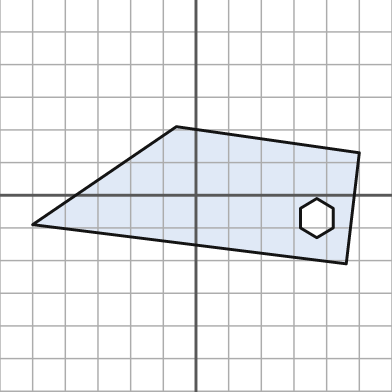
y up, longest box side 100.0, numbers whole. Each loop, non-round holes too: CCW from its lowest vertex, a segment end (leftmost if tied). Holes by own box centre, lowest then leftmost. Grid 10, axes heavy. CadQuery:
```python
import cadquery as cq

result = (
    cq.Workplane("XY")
    .moveTo(46.0, -21.0)
    .lineTo(50.0, 13.0)
    .lineTo(-6.0, 21.0)
    .lineTo(-50.0, -9.0)
    .close()
    .moveTo(37.0, -13.0)
    .lineTo(42.0, -10.0)
    .lineTo(42.0, -4.0)
    .lineTo(37.0, -1.0)
    .lineTo(32.0, -4.0)
    .lineTo(32.0, -10.0)
    .close()
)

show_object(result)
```